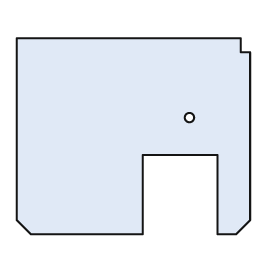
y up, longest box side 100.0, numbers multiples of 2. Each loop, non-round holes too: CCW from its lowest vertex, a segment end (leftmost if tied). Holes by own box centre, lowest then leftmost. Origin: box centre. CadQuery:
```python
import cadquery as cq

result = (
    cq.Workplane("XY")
    .moveTo(-44.0, -42.0)
    .lineTo(4.0, -42.0)
    .lineTo(4.0, -8.0)
    .lineTo(36.0, -8.0)
    .lineTo(36.0, -42.0)
    .lineTo(44.0, -42.0)
    .lineTo(50.0, -36.0)
    .lineTo(50.0, 36.0)
    .lineTo(46.0, 36.0)
    .lineTo(46.0, 42.0)
    .lineTo(-50.0, 42.0)
    .lineTo(-50.0, -36.0)
    .close()
    .moveTo(24.0, 8.0)
    .circle(2.0)
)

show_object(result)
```